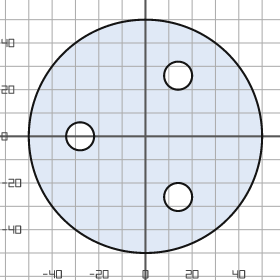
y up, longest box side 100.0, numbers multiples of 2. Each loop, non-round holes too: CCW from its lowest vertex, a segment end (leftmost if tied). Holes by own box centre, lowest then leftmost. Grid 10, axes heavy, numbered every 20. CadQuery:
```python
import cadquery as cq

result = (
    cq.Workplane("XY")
    .moveTo(0.0, 0.0)
    .circle(50.0)
    .moveTo(14.0, -26.0)
    .circle(6.0)
    .moveTo(-28.0, 0.0)
    .circle(6.0)
    .moveTo(14.0, 26.0)
    .circle(6.0)
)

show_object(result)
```